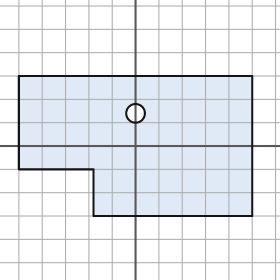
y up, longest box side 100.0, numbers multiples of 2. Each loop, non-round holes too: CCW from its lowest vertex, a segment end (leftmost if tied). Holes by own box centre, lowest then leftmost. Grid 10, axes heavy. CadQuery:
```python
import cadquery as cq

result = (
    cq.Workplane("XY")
    .moveTo(-18.0, -30.0)
    .lineTo(50.0, -30.0)
    .lineTo(50.0, 30.0)
    .lineTo(-50.0, 30.0)
    .lineTo(-50.0, -10.0)
    .lineTo(-18.0, -10.0)
    .close()
    .moveTo(0.0, 14.0)
    .circle(4.0)
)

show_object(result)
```